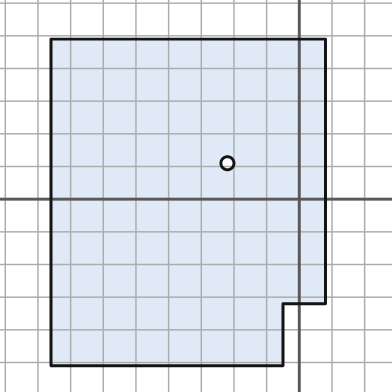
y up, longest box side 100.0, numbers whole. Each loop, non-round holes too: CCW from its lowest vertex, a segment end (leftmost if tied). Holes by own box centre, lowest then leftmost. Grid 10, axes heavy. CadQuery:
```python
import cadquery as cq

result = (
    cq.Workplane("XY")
    .moveTo(-76.0, -51.0)
    .lineTo(-5.0, -51.0)
    .lineTo(-5.0, -32.0)
    .lineTo(8.0, -32.0)
    .lineTo(8.0, 49.0)
    .lineTo(-76.0, 49.0)
    .close()
    .moveTo(-22.0, 11.0)
    .circle(2.0)
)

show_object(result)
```